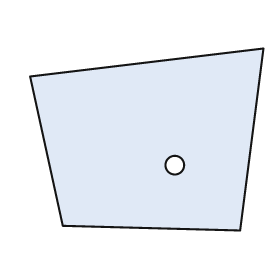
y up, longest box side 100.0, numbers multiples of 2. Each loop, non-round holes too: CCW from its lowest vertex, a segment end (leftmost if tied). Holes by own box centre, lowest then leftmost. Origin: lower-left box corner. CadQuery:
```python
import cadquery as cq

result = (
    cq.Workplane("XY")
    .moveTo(90.0, 0.0)
    .lineTo(100.0, 78.0)
    .lineTo(0.0, 66.0)
    .lineTo(14.0, 2.0)
    .close()
    .moveTo(62.0, 28.0)
    .circle(4.0)
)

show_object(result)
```